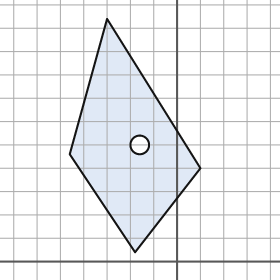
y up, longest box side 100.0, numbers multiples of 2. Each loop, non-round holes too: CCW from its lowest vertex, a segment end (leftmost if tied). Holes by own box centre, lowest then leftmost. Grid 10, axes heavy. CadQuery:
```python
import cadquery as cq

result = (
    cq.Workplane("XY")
    .moveTo(-18.0, 4.0)
    .lineTo(10.0, 40.0)
    .lineTo(-30.0, 104.0)
    .lineTo(-46.0, 46.0)
    .close()
    .moveTo(-16.0, 50.0)
    .circle(4.0)
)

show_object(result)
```